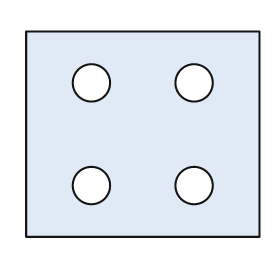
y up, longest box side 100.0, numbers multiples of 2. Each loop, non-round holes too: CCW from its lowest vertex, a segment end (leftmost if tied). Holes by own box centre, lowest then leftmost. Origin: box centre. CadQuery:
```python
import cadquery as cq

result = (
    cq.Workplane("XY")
    .moveTo(-50.0, -44.0)
    .lineTo(50.0, -44.0)
    .lineTo(50.0, 44.0)
    .lineTo(-50.0, 44.0)
    .close()
    .moveTo(-22.0, -22.0)
    .circle(8.0)
    .moveTo(22.0, -22.0)
    .circle(8.0)
    .moveTo(-22.0, 22.0)
    .circle(8.0)
    .moveTo(22.0, 22.0)
    .circle(8.0)
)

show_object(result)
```